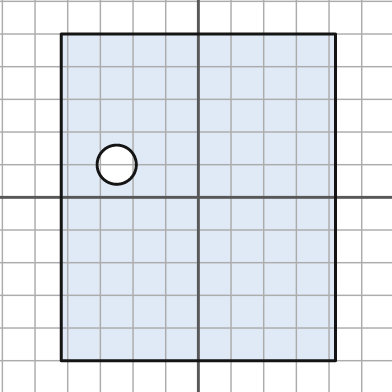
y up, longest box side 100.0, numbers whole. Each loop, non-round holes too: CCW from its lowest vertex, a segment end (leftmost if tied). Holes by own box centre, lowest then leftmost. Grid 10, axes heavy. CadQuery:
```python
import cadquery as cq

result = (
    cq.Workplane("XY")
    .moveTo(-42.0, -50.0)
    .lineTo(42.0, -50.0)
    .lineTo(42.0, 50.0)
    .lineTo(-42.0, 50.0)
    .close()
    .moveTo(-25.0, 10.0)
    .circle(6.0)
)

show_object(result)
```